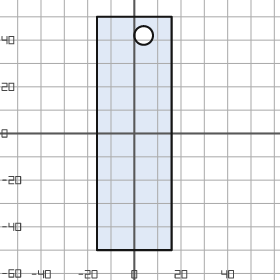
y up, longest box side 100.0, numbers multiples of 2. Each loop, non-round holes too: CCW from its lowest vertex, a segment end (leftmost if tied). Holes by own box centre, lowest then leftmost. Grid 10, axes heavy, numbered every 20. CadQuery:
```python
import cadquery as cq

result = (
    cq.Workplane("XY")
    .moveTo(-16.0, -50.0)
    .lineTo(16.0, -50.0)
    .lineTo(16.0, 50.0)
    .lineTo(-16.0, 50.0)
    .close()
    .moveTo(4.0, 42.0)
    .circle(4.0)
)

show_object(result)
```